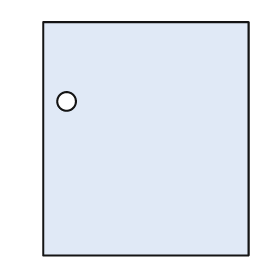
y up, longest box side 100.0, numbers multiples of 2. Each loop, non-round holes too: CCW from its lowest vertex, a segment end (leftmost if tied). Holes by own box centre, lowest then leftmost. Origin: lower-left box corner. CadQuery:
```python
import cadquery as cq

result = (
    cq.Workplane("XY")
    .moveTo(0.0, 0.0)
    .lineTo(88.0, 0.0)
    .lineTo(88.0, 100.0)
    .lineTo(0.0, 100.0)
    .close()
    .moveTo(10.0, 66.0)
    .circle(4.0)
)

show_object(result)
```